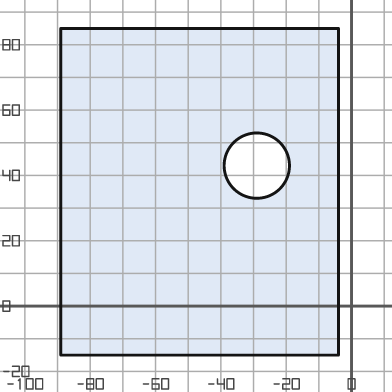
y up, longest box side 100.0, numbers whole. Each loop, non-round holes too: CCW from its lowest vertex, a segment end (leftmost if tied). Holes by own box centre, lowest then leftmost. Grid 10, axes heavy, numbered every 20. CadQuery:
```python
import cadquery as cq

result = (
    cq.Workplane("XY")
    .moveTo(-89.0, -15.0)
    .lineTo(-4.0, -15.0)
    .lineTo(-4.0, 85.0)
    .lineTo(-89.0, 85.0)
    .close()
    .moveTo(-29.0, 43.0)
    .circle(10.0)
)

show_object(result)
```